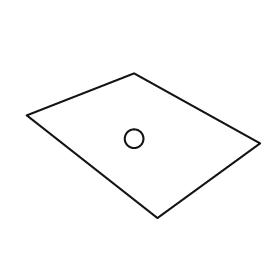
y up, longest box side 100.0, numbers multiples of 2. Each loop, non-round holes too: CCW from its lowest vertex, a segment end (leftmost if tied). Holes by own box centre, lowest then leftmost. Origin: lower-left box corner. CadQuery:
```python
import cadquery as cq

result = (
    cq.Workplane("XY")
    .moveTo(56.0, 0.0)
    .lineTo(100.0, 32.0)
    .lineTo(46.0, 62.0)
    .lineTo(0.0, 44.0)
    .close()
    .moveTo(46.0, 34.0)
    .circle(4.0)
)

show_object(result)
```